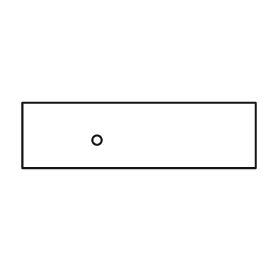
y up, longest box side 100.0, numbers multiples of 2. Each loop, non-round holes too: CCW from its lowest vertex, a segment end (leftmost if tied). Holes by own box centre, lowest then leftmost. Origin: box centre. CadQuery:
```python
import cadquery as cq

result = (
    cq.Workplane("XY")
    .moveTo(-50.0, -14.0)
    .lineTo(50.0, -14.0)
    .lineTo(50.0, 14.0)
    .lineTo(-50.0, 14.0)
    .close()
    .moveTo(-18.0, -2.0)
    .circle(2.0)
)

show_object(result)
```